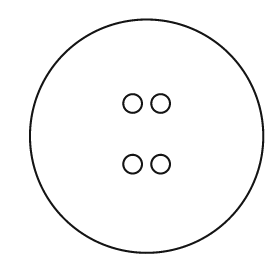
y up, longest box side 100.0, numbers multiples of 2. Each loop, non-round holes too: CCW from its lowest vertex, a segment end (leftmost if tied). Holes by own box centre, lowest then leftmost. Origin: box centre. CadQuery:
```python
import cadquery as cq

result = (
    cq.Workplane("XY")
    .moveTo(0.0, 0.0)
    .circle(50.0)
    .moveTo(-6.0, -12.0)
    .circle(4.0)
    .moveTo(6.0, -12.0)
    .circle(4.0)
    .moveTo(-6.0, 14.0)
    .circle(4.0)
    .moveTo(6.0, 14.0)
    .circle(4.0)
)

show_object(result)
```